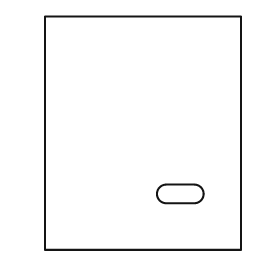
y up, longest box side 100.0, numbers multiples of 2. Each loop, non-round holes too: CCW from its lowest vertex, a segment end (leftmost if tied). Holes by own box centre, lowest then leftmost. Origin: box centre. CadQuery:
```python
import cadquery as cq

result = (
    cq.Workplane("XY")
    .moveTo(-42.0, -50.0)
    .lineTo(42.0, -50.0)
    .lineTo(42.0, 50.0)
    .lineTo(-42.0, 50.0)
    .close()
    .moveTo(10.0, -30.0)
    .lineTo(22.0, -30.0)
    .threePointArc((26.0, -26.0), (22.0, -22.0))
    .lineTo(10.0, -22.0)
    .threePointArc((6.0, -26.0), (10.0, -30.0))
    .close()
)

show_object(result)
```